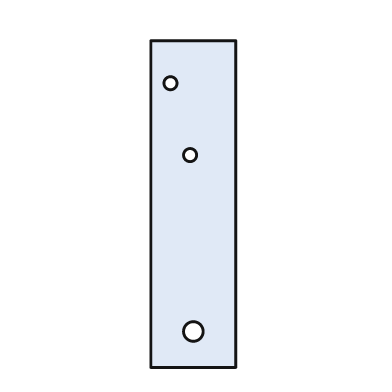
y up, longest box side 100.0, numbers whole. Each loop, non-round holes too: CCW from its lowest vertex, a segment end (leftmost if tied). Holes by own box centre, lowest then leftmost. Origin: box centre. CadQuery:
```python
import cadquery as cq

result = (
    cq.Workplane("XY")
    .moveTo(-13.0, -50.0)
    .lineTo(13.0, -50.0)
    .lineTo(13.0, 50.0)
    .lineTo(-13.0, 50.0)
    .close()
    .moveTo(0.0, -39.0)
    .circle(3.0)
    .moveTo(-1.0, 15.0)
    .circle(2.0)
    .moveTo(-7.0, 37.0)
    .circle(2.0)
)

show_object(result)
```